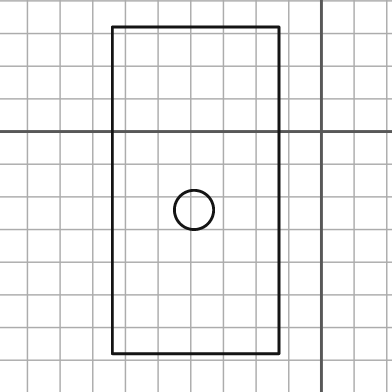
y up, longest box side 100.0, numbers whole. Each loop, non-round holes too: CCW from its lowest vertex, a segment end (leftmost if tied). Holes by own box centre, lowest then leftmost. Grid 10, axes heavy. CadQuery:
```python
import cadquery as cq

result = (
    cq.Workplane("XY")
    .moveTo(-64.0, -68.0)
    .lineTo(-13.0, -68.0)
    .lineTo(-13.0, 32.0)
    .lineTo(-64.0, 32.0)
    .close()
    .moveTo(-39.0, -24.0)
    .circle(6.0)
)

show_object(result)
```